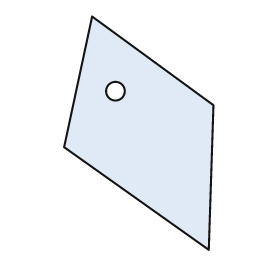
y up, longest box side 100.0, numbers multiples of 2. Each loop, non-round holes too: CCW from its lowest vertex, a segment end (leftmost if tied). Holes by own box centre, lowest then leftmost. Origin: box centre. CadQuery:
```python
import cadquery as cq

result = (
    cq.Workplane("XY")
    .moveTo(30.0, -50.0)
    .lineTo(32.0, 12.0)
    .lineTo(-20.0, 50.0)
    .lineTo(-32.0, -6.0)
    .close()
    .moveTo(-10.0, 18.0)
    .circle(4.0)
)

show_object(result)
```